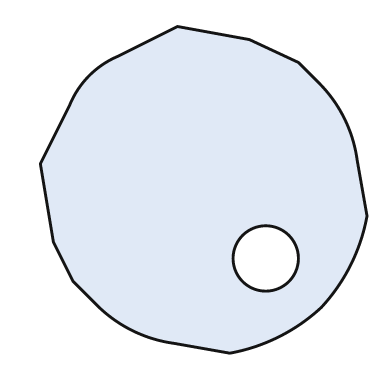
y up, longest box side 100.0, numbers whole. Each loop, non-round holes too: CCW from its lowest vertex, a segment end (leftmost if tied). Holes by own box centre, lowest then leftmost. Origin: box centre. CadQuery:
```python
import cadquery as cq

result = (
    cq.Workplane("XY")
    .moveTo(8.0, -50.0)
    .threePointArc((23.0, -45.0), (36.0, -36.0))
    .threePointArc((45.0, -23.0), (50.0, -8.0))
    .lineTo(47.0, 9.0)
    .threePointArc((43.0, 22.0), (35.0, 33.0))
    .lineTo(29.0, 39.0)
    .lineTo(14.0, 46.0)
    .lineTo(-8.0, 50.0)
    .lineTo(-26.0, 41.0)
    .threePointArc((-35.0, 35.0), (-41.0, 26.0))
    .lineTo(-50.0, 8.0)
    .lineTo(-46.0, -16.0)
    .lineTo(-40.0, -28.0)
    .lineTo(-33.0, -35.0)
    .threePointArc((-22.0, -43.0), (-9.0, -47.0))
    .close()
    .moveTo(19.0, -21.0)
    .circle(10.0)
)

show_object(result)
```